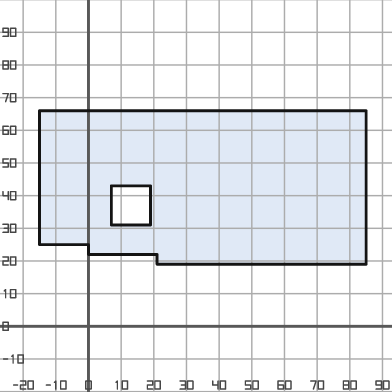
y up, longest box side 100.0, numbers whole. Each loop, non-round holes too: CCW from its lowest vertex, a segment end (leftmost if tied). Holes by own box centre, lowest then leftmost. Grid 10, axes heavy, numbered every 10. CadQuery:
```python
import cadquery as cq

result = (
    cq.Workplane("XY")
    .moveTo(21.0, 19.0)
    .lineTo(85.0, 19.0)
    .lineTo(85.0, 66.0)
    .lineTo(-15.0, 66.0)
    .lineTo(-15.0, 25.0)
    .lineTo(0.0, 25.0)
    .lineTo(0.0, 22.0)
    .lineTo(21.0, 22.0)
    .close()
    .moveTo(7.0, 31.0)
    .lineTo(19.0, 31.0)
    .lineTo(19.0, 43.0)
    .lineTo(7.0, 43.0)
    .close()
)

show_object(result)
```